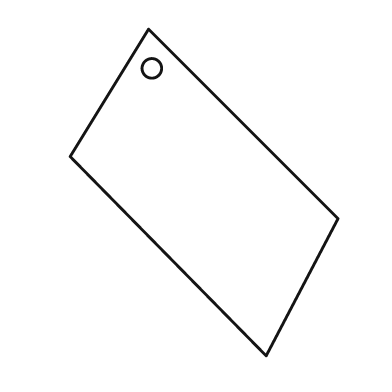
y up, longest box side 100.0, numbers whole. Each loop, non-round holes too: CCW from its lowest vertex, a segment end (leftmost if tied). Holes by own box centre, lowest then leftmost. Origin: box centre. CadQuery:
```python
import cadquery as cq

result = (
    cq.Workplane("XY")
    .moveTo(19.0, -50.0)
    .lineTo(41.0, -8.0)
    .lineTo(-17.0, 50.0)
    .lineTo(-41.0, 11.0)
    .close()
    .moveTo(-16.0, 38.0)
    .circle(3.0)
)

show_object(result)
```